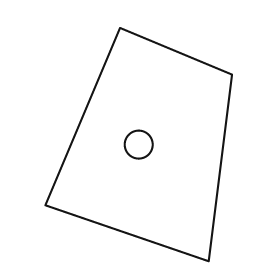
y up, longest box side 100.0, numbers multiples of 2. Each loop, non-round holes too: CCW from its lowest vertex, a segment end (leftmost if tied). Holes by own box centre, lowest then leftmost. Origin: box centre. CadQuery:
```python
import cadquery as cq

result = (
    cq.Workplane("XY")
    .moveTo(30.0, -50.0)
    .lineTo(40.0, 30.0)
    .lineTo(-8.0, 50.0)
    .lineTo(-40.0, -26.0)
    .close()
    .moveTo(0.0, 0.0)
    .circle(6.0)
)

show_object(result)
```